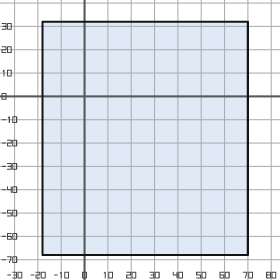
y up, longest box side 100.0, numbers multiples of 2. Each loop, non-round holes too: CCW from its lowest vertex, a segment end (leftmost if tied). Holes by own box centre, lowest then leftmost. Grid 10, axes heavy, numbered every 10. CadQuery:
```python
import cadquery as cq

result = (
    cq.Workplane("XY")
    .moveTo(-18.0, -68.0)
    .lineTo(70.0, -68.0)
    .lineTo(70.0, 32.0)
    .lineTo(-18.0, 32.0)
    .close()
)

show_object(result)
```